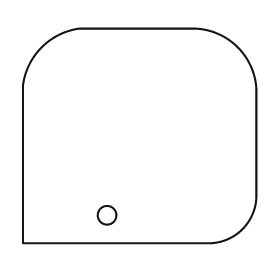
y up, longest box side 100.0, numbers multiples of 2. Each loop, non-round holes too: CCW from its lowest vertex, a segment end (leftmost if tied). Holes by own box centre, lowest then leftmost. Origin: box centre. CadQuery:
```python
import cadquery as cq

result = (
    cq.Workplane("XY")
    .moveTo(-50.0, -46.0)
    .lineTo(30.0, -46.0)
    .threePointArc((44.0, -40.0), (50.0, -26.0))
    .lineTo(50.0, 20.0)
    .threePointArc((42.0, 38.0), (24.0, 46.0))
    .lineTo(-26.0, 46.0)
    .threePointArc((-42.0, 38.0), (-50.0, 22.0))
    .close()
    .moveTo(-14.0, -34.0)
    .circle(4.0)
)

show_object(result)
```